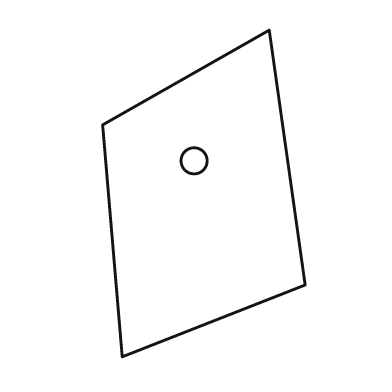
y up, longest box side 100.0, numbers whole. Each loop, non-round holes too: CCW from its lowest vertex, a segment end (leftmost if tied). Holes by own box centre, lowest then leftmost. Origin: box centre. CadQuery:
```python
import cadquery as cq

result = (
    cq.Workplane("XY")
    .moveTo(-25.0, -50.0)
    .lineTo(31.0, -28.0)
    .lineTo(20.0, 50.0)
    .lineTo(-31.0, 21.0)
    .close()
    .moveTo(-3.0, 10.0)
    .circle(4.0)
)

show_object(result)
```